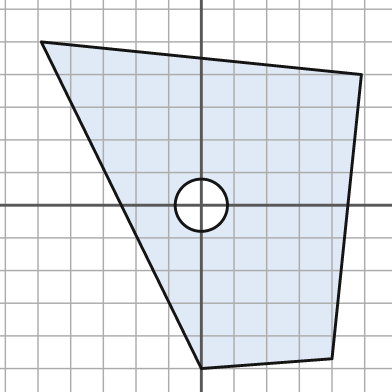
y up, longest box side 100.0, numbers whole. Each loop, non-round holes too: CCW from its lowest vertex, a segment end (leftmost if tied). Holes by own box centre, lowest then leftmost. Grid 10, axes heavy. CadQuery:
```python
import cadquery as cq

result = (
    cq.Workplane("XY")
    .moveTo(0.0, -50.0)
    .lineTo(40.0, -47.0)
    .lineTo(49.0, 40.0)
    .lineTo(-49.0, 50.0)
    .close()
    .moveTo(0.0, 0.0)
    .circle(8.0)
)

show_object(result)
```